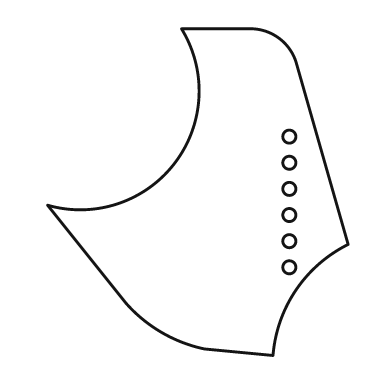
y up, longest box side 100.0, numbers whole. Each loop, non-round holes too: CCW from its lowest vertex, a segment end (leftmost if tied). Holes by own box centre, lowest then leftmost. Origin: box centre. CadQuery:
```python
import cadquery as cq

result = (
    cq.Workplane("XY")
    .moveTo(23.0, -50.0)
    .threePointArc((30.0, -30.0), (46.0, -16.0))
    .lineTo(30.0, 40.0)
    .threePointArc((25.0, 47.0), (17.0, 50.0))
    .lineTo(-5.0, 50.0)
    .threePointArc((-7.0, 9.0), (-46.0, -4.0))
    .lineTo(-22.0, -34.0)
    .threePointArc((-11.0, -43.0), (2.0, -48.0))
    .close()
    .moveTo(28.0, -23.0)
    .circle(2.0)
    .moveTo(28.0, -15.0)
    .circle(2.0)
    .moveTo(28.0, -7.0)
    .circle(2.0)
    .moveTo(28.0, 1.0)
    .circle(2.0)
    .moveTo(28.0, 9.0)
    .circle(2.0)
    .moveTo(28.0, 17.0)
    .circle(2.0)
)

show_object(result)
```